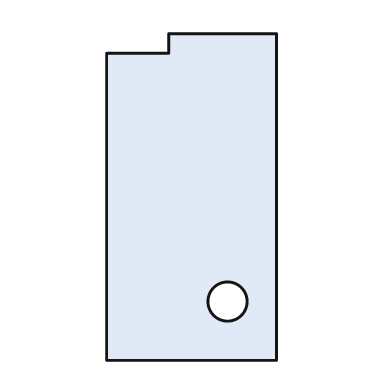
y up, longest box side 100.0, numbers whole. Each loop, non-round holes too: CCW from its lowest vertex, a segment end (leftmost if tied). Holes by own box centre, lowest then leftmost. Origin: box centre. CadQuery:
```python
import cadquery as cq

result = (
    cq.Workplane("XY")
    .moveTo(-26.0, -50.0)
    .lineTo(26.0, -50.0)
    .lineTo(26.0, 50.0)
    .lineTo(-7.0, 50.0)
    .lineTo(-7.0, 44.0)
    .lineTo(-26.0, 44.0)
    .close()
    .moveTo(11.0, -32.0)
    .circle(6.0)
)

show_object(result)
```